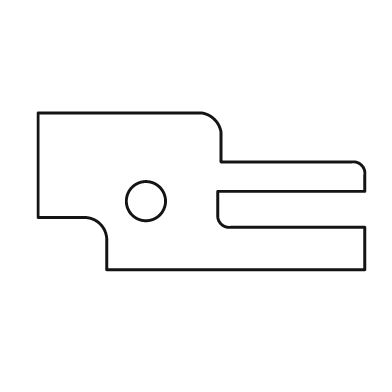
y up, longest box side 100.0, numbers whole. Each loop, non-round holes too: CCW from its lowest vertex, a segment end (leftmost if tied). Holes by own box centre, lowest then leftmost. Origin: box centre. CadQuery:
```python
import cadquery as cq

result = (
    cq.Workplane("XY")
    .moveTo(-29.0, -24.0)
    .lineTo(50.0, -24.0)
    .lineTo(50.0, -11.0)
    .lineTo(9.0, -11.0)
    .threePointArc((6.0, -10.0), (5.0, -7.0))
    .lineTo(5.0, 0.0)
    .lineTo(50.0, 0.0)
    .lineTo(50.0, 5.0)
    .threePointArc((49.0, 8.0), (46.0, 9.0))
    .lineTo(6.0, 9.0)
    .lineTo(6.0, 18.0)
    .threePointArc((4.0, 22.0), (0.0, 24.0))
    .lineTo(-50.0, 24.0)
    .lineTo(-50.0, -8.0)
    .lineTo(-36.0, -8.0)
    .threePointArc((-31.0, -10.0), (-29.0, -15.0))
    .close()
    .moveTo(-17.0, -3.0)
    .circle(6.0)
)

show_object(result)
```